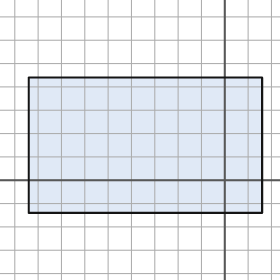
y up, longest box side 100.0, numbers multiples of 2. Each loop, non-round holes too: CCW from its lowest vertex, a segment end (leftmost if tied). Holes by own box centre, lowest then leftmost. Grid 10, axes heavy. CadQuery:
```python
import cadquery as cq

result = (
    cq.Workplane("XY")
    .moveTo(-84.0, -14.0)
    .lineTo(16.0, -14.0)
    .lineTo(16.0, 44.0)
    .lineTo(-84.0, 44.0)
    .close()
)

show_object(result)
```